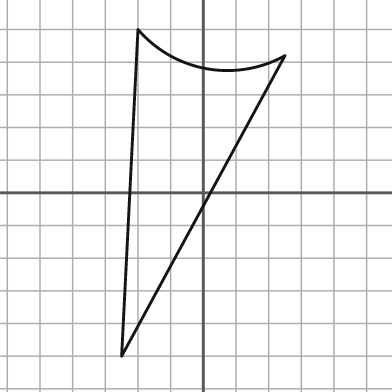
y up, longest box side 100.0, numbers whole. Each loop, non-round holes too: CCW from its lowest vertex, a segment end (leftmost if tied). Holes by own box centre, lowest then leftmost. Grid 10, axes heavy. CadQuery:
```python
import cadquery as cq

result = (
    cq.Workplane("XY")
    .moveTo(-25.0, -50.0)
    .lineTo(25.0, 42.0)
    .threePointArc((1.0, 38.0), (-20.0, 50.0))
    .close()
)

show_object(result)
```